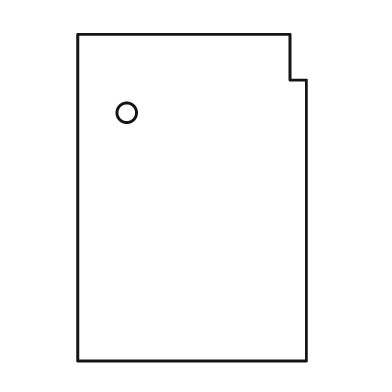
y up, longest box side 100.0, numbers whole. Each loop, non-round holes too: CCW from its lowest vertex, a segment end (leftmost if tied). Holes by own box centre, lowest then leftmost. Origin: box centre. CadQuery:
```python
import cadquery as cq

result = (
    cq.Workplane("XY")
    .moveTo(-35.0, -50.0)
    .lineTo(35.0, -50.0)
    .lineTo(35.0, 36.0)
    .lineTo(30.0, 36.0)
    .lineTo(30.0, 50.0)
    .lineTo(-35.0, 50.0)
    .close()
    .moveTo(-20.0, 26.0)
    .circle(3.0)
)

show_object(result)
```